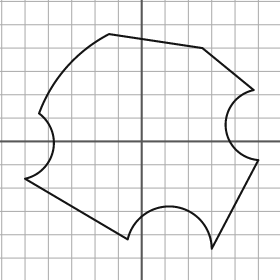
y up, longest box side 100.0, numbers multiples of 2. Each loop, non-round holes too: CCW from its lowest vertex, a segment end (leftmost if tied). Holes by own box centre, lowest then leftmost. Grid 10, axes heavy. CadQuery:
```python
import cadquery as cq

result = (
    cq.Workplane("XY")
    .moveTo(30.0, -46.0)
    .lineTo(50.0, -8.0)
    .threePointArc((36.0, 6.0), (48.0, 22.0))
    .lineTo(26.0, 40.0)
    .lineTo(-14.0, 46.0)
    .threePointArc((-32.0, 32.0), (-44.0, 12.0))
    .threePointArc((-38.0, -4.0), (-50.0, -16.0))
    .lineTo(-6.0, -42.0)
    .threePointArc((14.0, -28.0), (30.0, -46.0))
    .close()
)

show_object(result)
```